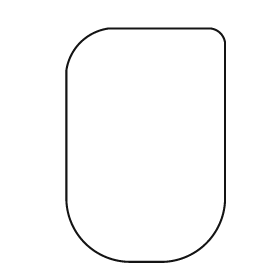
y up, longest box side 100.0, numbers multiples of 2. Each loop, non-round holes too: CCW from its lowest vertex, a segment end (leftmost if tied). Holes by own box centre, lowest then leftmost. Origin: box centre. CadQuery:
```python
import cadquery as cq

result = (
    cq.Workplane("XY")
    .moveTo(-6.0, -50.0)
    .lineTo(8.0, -50.0)
    .threePointArc((26.0, -42.0), (34.0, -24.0))
    .lineTo(34.0, 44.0)
    .threePointArc((32.0, 48.0), (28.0, 50.0))
    .lineTo(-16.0, 50.0)
    .threePointArc((-28.0, 44.0), (-34.0, 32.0))
    .lineTo(-34.0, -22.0)
    .threePointArc((-26.0, -42.0), (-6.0, -50.0))
    .close()
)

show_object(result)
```